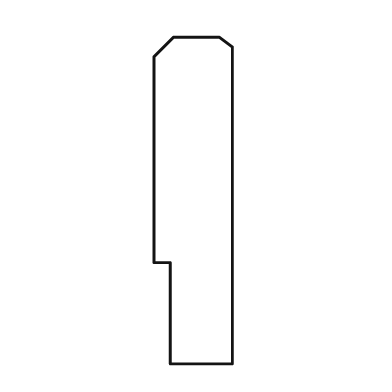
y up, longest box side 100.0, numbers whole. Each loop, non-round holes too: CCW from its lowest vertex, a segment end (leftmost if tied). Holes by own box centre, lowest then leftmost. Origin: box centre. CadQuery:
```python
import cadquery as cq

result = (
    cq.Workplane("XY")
    .moveTo(-7.0, -50.0)
    .lineTo(12.0, -50.0)
    .lineTo(12.0, 47.0)
    .lineTo(8.0, 50.0)
    .lineTo(-6.0, 50.0)
    .lineTo(-12.0, 44.0)
    .lineTo(-12.0, -19.0)
    .lineTo(-7.0, -19.0)
    .close()
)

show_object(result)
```